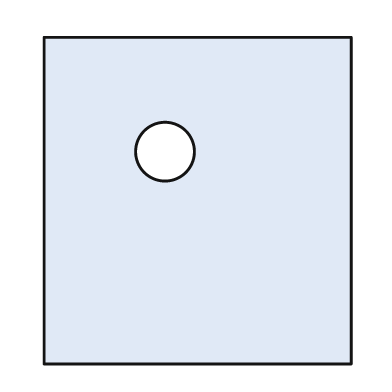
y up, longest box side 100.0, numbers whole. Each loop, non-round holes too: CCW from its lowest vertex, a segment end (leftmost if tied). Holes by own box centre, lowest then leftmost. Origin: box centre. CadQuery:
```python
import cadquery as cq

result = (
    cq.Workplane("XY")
    .moveTo(-47.0, -50.0)
    .lineTo(47.0, -50.0)
    .lineTo(47.0, 50.0)
    .lineTo(-47.0, 50.0)
    .close()
    .moveTo(-10.0, 15.0)
    .circle(9.0)
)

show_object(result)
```